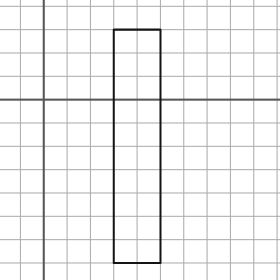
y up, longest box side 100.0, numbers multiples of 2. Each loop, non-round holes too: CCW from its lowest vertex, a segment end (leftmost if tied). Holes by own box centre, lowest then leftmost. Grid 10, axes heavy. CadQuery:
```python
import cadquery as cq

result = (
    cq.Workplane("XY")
    .moveTo(30.0, -70.0)
    .lineTo(50.0, -70.0)
    .lineTo(50.0, 30.0)
    .lineTo(30.0, 30.0)
    .close()
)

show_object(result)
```